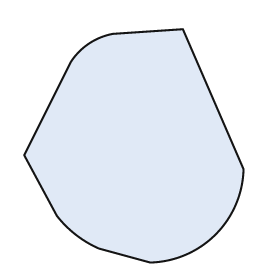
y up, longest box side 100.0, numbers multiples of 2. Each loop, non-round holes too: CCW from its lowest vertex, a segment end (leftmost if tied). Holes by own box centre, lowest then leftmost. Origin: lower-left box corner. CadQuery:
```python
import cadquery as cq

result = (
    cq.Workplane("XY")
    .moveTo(54.0, 0.0)
    .threePointArc((82.0, 12.0), (94.0, 40.0))
    .lineTo(68.0, 100.0)
    .lineTo(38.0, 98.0)
    .threePointArc((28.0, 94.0), (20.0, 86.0))
    .lineTo(0.0, 46.0)
    .lineTo(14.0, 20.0)
    .threePointArc((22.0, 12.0), (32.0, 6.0))
    .close()
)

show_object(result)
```